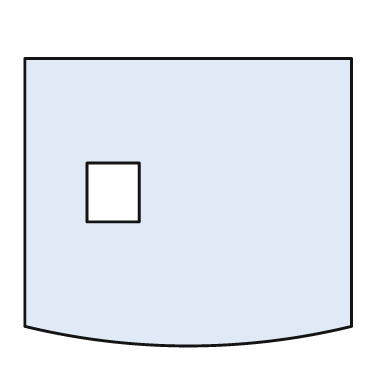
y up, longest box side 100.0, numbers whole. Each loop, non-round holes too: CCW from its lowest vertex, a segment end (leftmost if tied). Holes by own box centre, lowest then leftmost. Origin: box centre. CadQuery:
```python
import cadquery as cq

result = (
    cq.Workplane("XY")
    .moveTo(-50.0, -38.0)
    .threePointArc((0.0, -44.0), (50.0, -38.0))
    .lineTo(50.0, 44.0)
    .lineTo(-50.0, 44.0)
    .close()
    .moveTo(-31.0, -6.0)
    .lineTo(-15.0, -6.0)
    .lineTo(-15.0, 12.0)
    .lineTo(-31.0, 12.0)
    .close()
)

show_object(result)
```